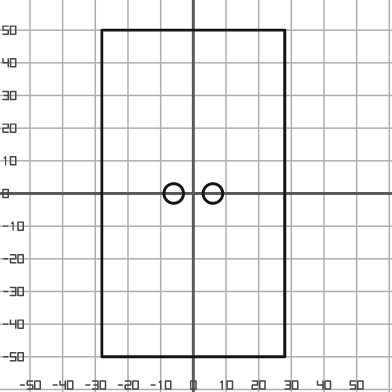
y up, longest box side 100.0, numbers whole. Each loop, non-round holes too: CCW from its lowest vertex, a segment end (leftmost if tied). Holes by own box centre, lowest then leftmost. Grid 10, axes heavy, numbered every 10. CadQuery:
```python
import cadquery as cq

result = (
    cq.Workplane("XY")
    .moveTo(-28.0, -50.0)
    .lineTo(28.0, -50.0)
    .lineTo(28.0, 50.0)
    .lineTo(-28.0, 50.0)
    .close()
    .moveTo(-6.0, 0.0)
    .circle(3.0)
    .moveTo(6.0, 0.0)
    .circle(3.0)
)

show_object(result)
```